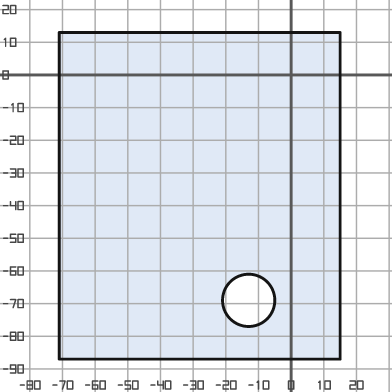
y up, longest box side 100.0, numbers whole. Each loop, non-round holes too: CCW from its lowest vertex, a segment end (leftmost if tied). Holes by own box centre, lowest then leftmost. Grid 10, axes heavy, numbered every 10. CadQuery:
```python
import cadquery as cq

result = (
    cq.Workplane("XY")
    .moveTo(-71.0, -87.0)
    .lineTo(15.0, -87.0)
    .lineTo(15.0, 13.0)
    .lineTo(-71.0, 13.0)
    .close()
    .moveTo(-13.0, -69.0)
    .circle(8.0)
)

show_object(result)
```